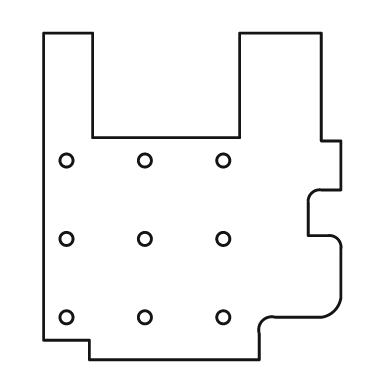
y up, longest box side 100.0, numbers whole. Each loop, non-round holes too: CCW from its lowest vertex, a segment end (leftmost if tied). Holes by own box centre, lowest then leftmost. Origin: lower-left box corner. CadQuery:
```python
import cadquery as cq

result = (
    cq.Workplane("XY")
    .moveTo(14.0, 0.0)
    .lineTo(66.0, 0.0)
    .lineTo(66.0, 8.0)
    .threePointArc((67.0, 12.0), (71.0, 13.0))
    .lineTo(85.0, 13.0)
    .threePointArc((89.0, 15.0), (91.0, 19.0))
    .lineTo(91.0, 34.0)
    .threePointArc((90.0, 37.0), (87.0, 38.0))
    .lineTo(81.0, 38.0)
    .lineTo(81.0, 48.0)
    .threePointArc((82.0, 51.0), (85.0, 52.0))
    .lineTo(91.0, 52.0)
    .lineTo(91.0, 67.0)
    .lineTo(85.0, 67.0)
    .lineTo(85.0, 100.0)
    .lineTo(60.0, 100.0)
    .lineTo(60.0, 68.0)
    .lineTo(15.0, 68.0)
    .lineTo(15.0, 100.0)
    .lineTo(0.0, 100.0)
    .lineTo(0.0, 6.0)
    .lineTo(14.0, 6.0)
    .close()
    .moveTo(7.0, 13.0)
    .circle(2.0)
    .moveTo(31.0, 13.0)
    .circle(2.0)
    .moveTo(55.0, 13.0)
    .circle(2.0)
    .moveTo(7.0, 37.0)
    .circle(2.0)
    .moveTo(31.0, 37.0)
    .circle(2.0)
    .moveTo(55.0, 37.0)
    .circle(2.0)
    .moveTo(7.0, 61.0)
    .circle(2.0)
    .moveTo(31.0, 61.0)
    .circle(2.0)
    .moveTo(55.0, 61.0)
    .circle(2.0)
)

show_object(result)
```